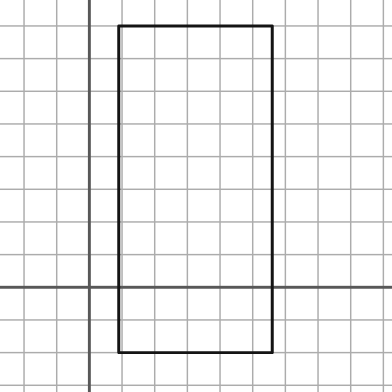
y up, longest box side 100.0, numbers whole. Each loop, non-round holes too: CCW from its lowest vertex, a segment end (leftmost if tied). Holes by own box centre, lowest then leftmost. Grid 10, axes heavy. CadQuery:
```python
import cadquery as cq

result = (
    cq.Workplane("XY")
    .moveTo(9.0, -20.0)
    .lineTo(56.0, -20.0)
    .lineTo(56.0, 80.0)
    .lineTo(9.0, 80.0)
    .close()
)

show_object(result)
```